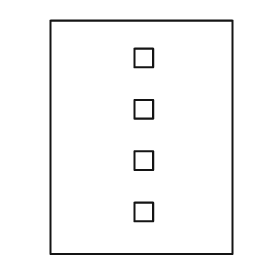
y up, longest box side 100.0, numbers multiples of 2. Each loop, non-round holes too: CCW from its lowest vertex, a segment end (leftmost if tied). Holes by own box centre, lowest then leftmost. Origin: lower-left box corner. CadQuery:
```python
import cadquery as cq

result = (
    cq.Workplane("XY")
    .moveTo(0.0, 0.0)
    .lineTo(78.0, 0.0)
    .lineTo(78.0, 100.0)
    .lineTo(0.0, 100.0)
    .close()
    .moveTo(36.0, 14.0)
    .lineTo(44.0, 14.0)
    .lineTo(44.0, 22.0)
    .lineTo(36.0, 22.0)
    .close()
    .moveTo(36.0, 36.0)
    .lineTo(44.0, 36.0)
    .lineTo(44.0, 44.0)
    .lineTo(36.0, 44.0)
    .close()
    .moveTo(36.0, 58.0)
    .lineTo(44.0, 58.0)
    .lineTo(44.0, 66.0)
    .lineTo(36.0, 66.0)
    .close()
    .moveTo(36.0, 80.0)
    .lineTo(44.0, 80.0)
    .lineTo(44.0, 88.0)
    .lineTo(36.0, 88.0)
    .close()
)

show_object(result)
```